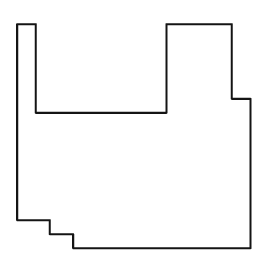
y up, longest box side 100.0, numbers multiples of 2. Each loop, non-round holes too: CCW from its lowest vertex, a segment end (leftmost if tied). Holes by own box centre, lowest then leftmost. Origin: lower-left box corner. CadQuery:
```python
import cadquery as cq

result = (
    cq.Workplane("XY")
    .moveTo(24.0, 0.0)
    .lineTo(100.0, 0.0)
    .lineTo(100.0, 64.0)
    .lineTo(92.0, 64.0)
    .lineTo(92.0, 96.0)
    .lineTo(64.0, 96.0)
    .lineTo(64.0, 58.0)
    .lineTo(8.0, 58.0)
    .lineTo(8.0, 96.0)
    .lineTo(0.0, 96.0)
    .lineTo(0.0, 12.0)
    .lineTo(14.0, 12.0)
    .lineTo(14.0, 6.0)
    .lineTo(24.0, 6.0)
    .close()
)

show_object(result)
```